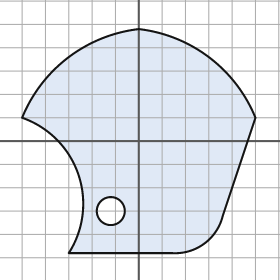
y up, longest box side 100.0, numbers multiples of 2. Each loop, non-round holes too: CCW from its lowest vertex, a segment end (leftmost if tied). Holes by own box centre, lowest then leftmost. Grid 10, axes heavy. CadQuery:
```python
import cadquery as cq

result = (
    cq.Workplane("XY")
    .moveTo(-30.0, -48.0)
    .lineTo(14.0, -48.0)
    .threePointArc((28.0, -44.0), (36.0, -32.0))
    .lineTo(50.0, 10.0)
    .threePointArc((30.0, 36.0), (0.0, 48.0))
    .threePointArc((-30.0, 36.0), (-50.0, 10.0))
    .threePointArc((-26.0, -14.0), (-30.0, -48.0))
    .close()
    .moveTo(-12.0, -30.0)
    .circle(6.0)
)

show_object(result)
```